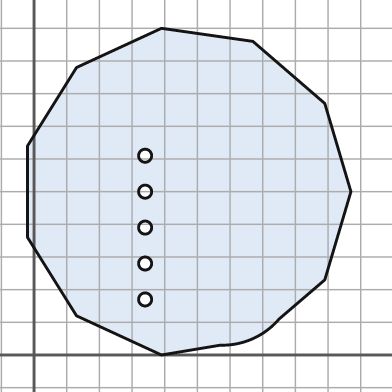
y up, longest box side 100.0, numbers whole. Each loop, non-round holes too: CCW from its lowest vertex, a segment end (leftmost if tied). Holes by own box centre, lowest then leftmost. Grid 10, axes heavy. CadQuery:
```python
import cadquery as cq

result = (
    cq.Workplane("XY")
    .moveTo(39.0, 0.0)
    .lineTo(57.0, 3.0)
    .threePointArc((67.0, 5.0), (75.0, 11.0))
    .lineTo(89.0, 23.0)
    .lineTo(97.0, 50.0)
    .lineTo(89.0, 77.0)
    .lineTo(67.0, 96.0)
    .lineTo(39.0, 100.0)
    .lineTo(13.0, 88.0)
    .lineTo(-2.0, 64.0)
    .lineTo(-2.0, 36.0)
    .lineTo(13.0, 12.0)
    .close()
    .moveTo(34.0, 17.0)
    .circle(2.0)
    .moveTo(34.0, 28.0)
    .circle(2.0)
    .moveTo(34.0, 39.0)
    .circle(2.0)
    .moveTo(34.0, 50.0)
    .circle(2.0)
    .moveTo(34.0, 61.0)
    .circle(2.0)
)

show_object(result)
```